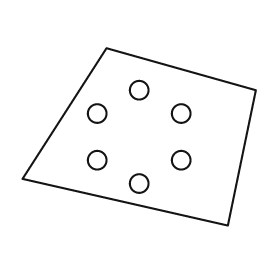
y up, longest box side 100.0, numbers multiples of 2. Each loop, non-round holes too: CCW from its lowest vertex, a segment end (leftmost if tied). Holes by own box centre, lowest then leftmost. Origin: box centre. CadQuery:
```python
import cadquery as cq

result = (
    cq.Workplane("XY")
    .moveTo(38.0, -38.0)
    .lineTo(50.0, 20.0)
    .lineTo(-14.0, 38.0)
    .lineTo(-50.0, -18.0)
    .close()
    .moveTo(0.0, -20.0)
    .circle(4.0)
    .moveTo(-18.0, -10.0)
    .circle(4.0)
    .moveTo(18.0, -10.0)
    .circle(4.0)
    .moveTo(-18.0, 10.0)
    .circle(4.0)
    .moveTo(18.0, 10.0)
    .circle(4.0)
    .moveTo(0.0, 20.0)
    .circle(4.0)
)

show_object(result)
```